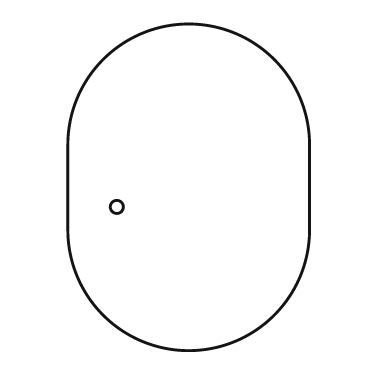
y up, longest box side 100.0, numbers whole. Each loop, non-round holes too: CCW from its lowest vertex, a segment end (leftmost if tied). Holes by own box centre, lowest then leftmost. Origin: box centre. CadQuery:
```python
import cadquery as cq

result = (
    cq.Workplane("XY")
    .moveTo(-37.0, -13.0)
    .threePointArc((0.0, -50.0), (37.0, -13.0))
    .lineTo(37.0, 13.0)
    .threePointArc((0.0, 50.0), (-37.0, 13.0))
    .close()
    .moveTo(-22.0, -6.0)
    .circle(2.0)
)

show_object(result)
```